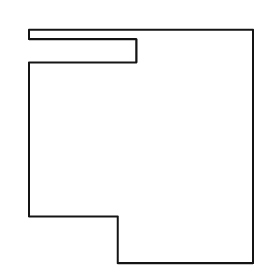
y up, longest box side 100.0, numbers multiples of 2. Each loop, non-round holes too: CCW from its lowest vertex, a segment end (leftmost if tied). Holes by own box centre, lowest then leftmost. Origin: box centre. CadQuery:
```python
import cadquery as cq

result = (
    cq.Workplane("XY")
    .moveTo(-10.0, -50.0)
    .lineTo(48.0, -50.0)
    .lineTo(48.0, 50.0)
    .lineTo(-48.0, 50.0)
    .lineTo(-48.0, 46.0)
    .lineTo(-2.0, 46.0)
    .lineTo(-2.0, 36.0)
    .lineTo(-48.0, 36.0)
    .lineTo(-48.0, -30.0)
    .lineTo(-10.0, -30.0)
    .close()
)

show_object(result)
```